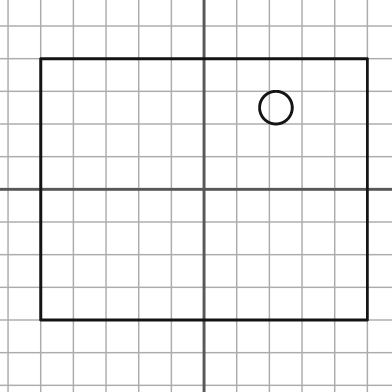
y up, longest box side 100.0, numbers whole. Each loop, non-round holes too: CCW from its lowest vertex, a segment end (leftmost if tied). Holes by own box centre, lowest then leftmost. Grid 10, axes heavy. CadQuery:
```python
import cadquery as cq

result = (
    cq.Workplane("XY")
    .moveTo(-50.0, -40.0)
    .lineTo(50.0, -40.0)
    .lineTo(50.0, 40.0)
    .lineTo(-50.0, 40.0)
    .close()
    .moveTo(22.0, 25.0)
    .circle(5.0)
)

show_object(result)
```